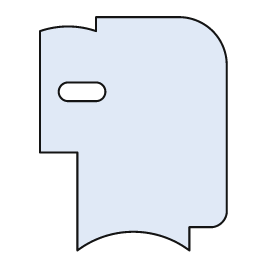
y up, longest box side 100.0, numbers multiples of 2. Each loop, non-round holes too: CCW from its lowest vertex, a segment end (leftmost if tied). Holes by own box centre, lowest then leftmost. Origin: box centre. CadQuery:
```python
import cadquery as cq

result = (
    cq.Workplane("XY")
    .moveTo(-24.0, -50.0)
    .threePointArc((0.0, -42.0), (24.0, -50.0))
    .lineTo(24.0, -40.0)
    .lineTo(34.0, -40.0)
    .threePointArc((38.0, -38.0), (40.0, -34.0))
    .lineTo(40.0, 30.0)
    .threePointArc((34.0, 44.0), (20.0, 50.0))
    .lineTo(-16.0, 50.0)
    .lineTo(-16.0, 44.0)
    .threePointArc((-28.0, 46.0), (-40.0, 44.0))
    .lineTo(-40.0, -8.0)
    .lineTo(-24.0, -8.0)
    .close()
    .moveTo(-28.0, 14.0)
    .lineTo(-16.0, 14.0)
    .threePointArc((-12.0, 18.0), (-16.0, 22.0))
    .lineTo(-28.0, 22.0)
    .threePointArc((-32.0, 18.0), (-28.0, 14.0))
    .close()
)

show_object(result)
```